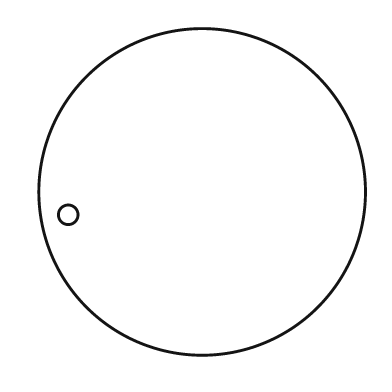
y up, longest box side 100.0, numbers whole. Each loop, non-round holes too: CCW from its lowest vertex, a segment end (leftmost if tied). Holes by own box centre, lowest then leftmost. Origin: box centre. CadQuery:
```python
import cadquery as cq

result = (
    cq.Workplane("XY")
    .moveTo(0.0, 0.0)
    .circle(50.0)
    .moveTo(-41.0, -7.0)
    .circle(3.0)
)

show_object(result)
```